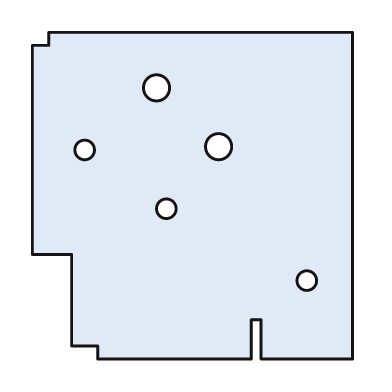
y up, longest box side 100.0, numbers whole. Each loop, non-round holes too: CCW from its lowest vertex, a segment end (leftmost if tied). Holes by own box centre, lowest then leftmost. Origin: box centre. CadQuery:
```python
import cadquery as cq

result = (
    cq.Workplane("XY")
    .moveTo(-29.0, -50.0)
    .lineTo(18.0, -50.0)
    .lineTo(18.0, -38.0)
    .lineTo(21.0, -38.0)
    .lineTo(21.0, -50.0)
    .lineTo(49.0, -50.0)
    .lineTo(49.0, 50.0)
    .lineTo(-44.0, 50.0)
    .lineTo(-44.0, 46.0)
    .lineTo(-49.0, 46.0)
    .lineTo(-49.0, -18.0)
    .lineTo(-37.0, -18.0)
    .lineTo(-37.0, -46.0)
    .lineTo(-29.0, -46.0)
    .close()
    .moveTo(35.0, -26.0)
    .circle(3.0)
    .moveTo(-8.0, -4.0)
    .circle(3.0)
    .moveTo(-33.0, 14.0)
    .circle(3.0)
    .moveTo(8.0, 15.0)
    .circle(4.0)
    .moveTo(-11.0, 33.0)
    .circle(4.0)
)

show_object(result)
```